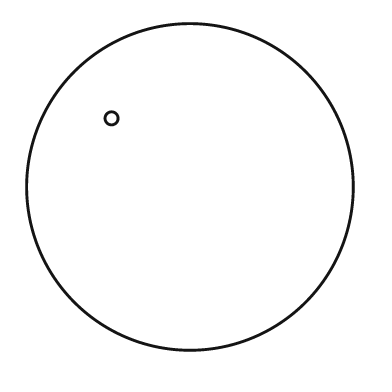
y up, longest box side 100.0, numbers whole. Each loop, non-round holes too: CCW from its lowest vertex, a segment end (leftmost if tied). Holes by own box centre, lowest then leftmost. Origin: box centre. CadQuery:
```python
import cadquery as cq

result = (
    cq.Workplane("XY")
    .moveTo(0.0, 0.0)
    .circle(50.0)
    .moveTo(-24.0, 21.0)
    .circle(2.0)
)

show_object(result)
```